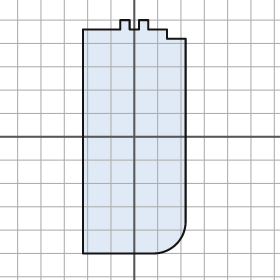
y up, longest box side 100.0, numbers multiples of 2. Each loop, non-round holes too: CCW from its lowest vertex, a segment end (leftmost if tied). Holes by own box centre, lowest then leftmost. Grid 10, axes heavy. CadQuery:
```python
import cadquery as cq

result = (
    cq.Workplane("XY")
    .moveTo(-22.0, -50.0)
    .lineTo(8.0, -50.0)
    .threePointArc((18.0, -46.0), (22.0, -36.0))
    .lineTo(22.0, 42.0)
    .lineTo(14.0, 42.0)
    .lineTo(14.0, 46.0)
    .lineTo(6.0, 46.0)
    .lineTo(6.0, 50.0)
    .lineTo(2.0, 50.0)
    .lineTo(2.0, 46.0)
    .lineTo(-2.0, 46.0)
    .lineTo(-2.0, 50.0)
    .lineTo(-6.0, 50.0)
    .lineTo(-6.0, 46.0)
    .lineTo(-22.0, 46.0)
    .close()
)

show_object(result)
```